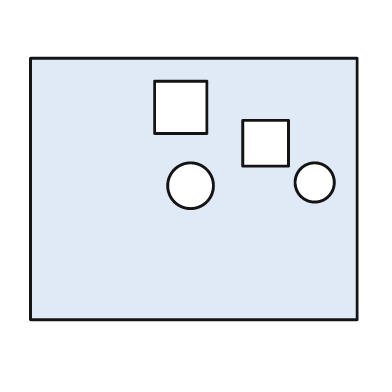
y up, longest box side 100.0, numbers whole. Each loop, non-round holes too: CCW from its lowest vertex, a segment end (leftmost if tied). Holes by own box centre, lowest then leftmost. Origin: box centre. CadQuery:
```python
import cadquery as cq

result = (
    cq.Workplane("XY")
    .moveTo(-50.0, -40.0)
    .lineTo(50.0, -40.0)
    .lineTo(50.0, 40.0)
    .lineTo(-50.0, 40.0)
    .close()
    .moveTo(-1.0, 1.0)
    .circle(7.0)
    .moveTo(37.0, 2.0)
    .circle(6.0)
    .moveTo(15.0, 7.0)
    .lineTo(29.0, 7.0)
    .lineTo(29.0, 21.0)
    .lineTo(15.0, 21.0)
    .close()
    .moveTo(-12.0, 17.0)
    .lineTo(4.0, 17.0)
    .lineTo(4.0, 33.0)
    .lineTo(-12.0, 33.0)
    .close()
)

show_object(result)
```